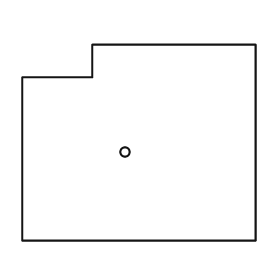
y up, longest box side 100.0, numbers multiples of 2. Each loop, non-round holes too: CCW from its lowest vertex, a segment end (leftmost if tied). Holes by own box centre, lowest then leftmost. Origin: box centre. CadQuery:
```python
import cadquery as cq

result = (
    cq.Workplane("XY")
    .moveTo(-50.0, -42.0)
    .lineTo(50.0, -42.0)
    .lineTo(50.0, 42.0)
    .lineTo(-20.0, 42.0)
    .lineTo(-20.0, 28.0)
    .lineTo(-50.0, 28.0)
    .close()
    .moveTo(-6.0, -4.0)
    .circle(2.0)
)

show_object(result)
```